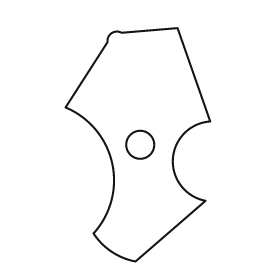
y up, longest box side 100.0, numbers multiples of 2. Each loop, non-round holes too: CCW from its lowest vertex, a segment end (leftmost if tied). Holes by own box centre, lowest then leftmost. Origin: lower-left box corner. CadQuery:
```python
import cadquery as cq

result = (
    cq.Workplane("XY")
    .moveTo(30.0, 0.0)
    .lineTo(60.0, 26.0)
    .threePointArc((46.0, 44.0), (62.0, 60.0))
    .lineTo(48.0, 100.0)
    .lineTo(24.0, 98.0)
    .threePointArc((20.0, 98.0), (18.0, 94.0))
    .lineTo(0.0, 66.0)
    .threePointArc((20.0, 42.0), (12.0, 12.0))
    .threePointArc((20.0, 4.0), (30.0, 0.0))
    .close()
    .moveTo(32.0, 50.0)
    .circle(6.0)
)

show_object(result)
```